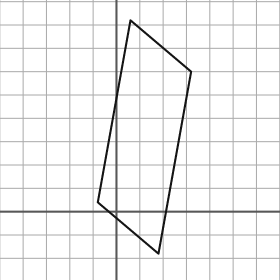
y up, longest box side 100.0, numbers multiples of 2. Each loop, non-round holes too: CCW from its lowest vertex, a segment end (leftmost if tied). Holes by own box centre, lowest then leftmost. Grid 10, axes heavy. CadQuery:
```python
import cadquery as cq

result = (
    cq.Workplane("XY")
    .moveTo(18.0, -18.0)
    .lineTo(32.0, 60.0)
    .lineTo(6.0, 82.0)
    .lineTo(-8.0, 4.0)
    .close()
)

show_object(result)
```